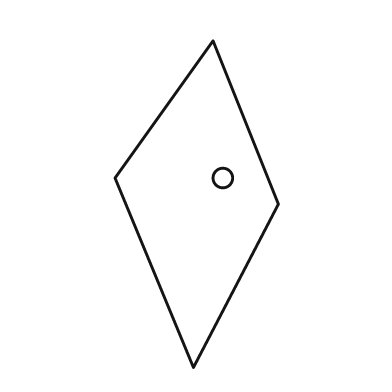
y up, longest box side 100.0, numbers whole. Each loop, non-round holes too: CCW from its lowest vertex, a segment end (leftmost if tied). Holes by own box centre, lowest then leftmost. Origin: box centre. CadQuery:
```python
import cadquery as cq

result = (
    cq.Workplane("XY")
    .moveTo(-1.0, -50.0)
    .lineTo(25.0, 0.0)
    .lineTo(5.0, 50.0)
    .lineTo(-25.0, 8.0)
    .close()
    .moveTo(8.0, 8.0)
    .circle(3.0)
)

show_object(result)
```